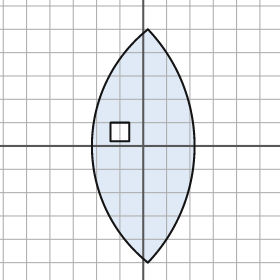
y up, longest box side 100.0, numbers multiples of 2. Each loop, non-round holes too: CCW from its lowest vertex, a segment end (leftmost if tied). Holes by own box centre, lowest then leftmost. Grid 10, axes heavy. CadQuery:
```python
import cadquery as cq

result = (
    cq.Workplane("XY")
    .moveTo(2.0, -50.0)
    .threePointArc((22.0, 0.0), (2.0, 50.0))
    .threePointArc((-22.0, 0.0), (2.0, -50.0))
    .close()
    .moveTo(-14.0, 2.0)
    .lineTo(-6.0, 2.0)
    .lineTo(-6.0, 10.0)
    .lineTo(-14.0, 10.0)
    .close()
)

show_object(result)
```